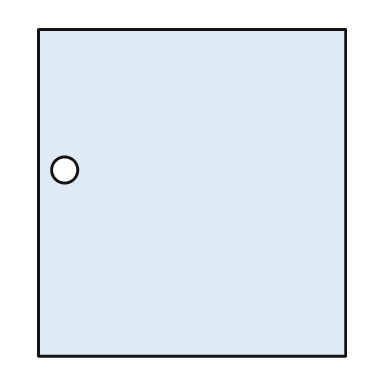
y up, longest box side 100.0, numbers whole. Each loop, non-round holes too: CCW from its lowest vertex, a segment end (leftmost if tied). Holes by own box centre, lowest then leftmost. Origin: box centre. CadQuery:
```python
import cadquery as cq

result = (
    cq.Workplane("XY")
    .moveTo(-47.0, -50.0)
    .lineTo(47.0, -50.0)
    .lineTo(47.0, 50.0)
    .lineTo(-47.0, 50.0)
    .close()
    .moveTo(-39.0, 7.0)
    .circle(4.0)
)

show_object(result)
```